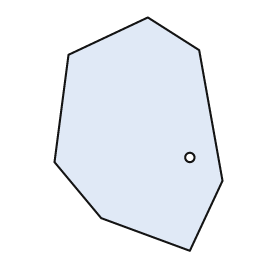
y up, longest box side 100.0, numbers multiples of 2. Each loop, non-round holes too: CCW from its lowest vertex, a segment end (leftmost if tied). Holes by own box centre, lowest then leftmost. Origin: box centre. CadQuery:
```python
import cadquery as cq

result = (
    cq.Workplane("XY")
    .moveTo(22.0, -50.0)
    .lineTo(36.0, -20.0)
    .lineTo(26.0, 36.0)
    .lineTo(4.0, 50.0)
    .lineTo(-30.0, 34.0)
    .lineTo(-36.0, -12.0)
    .lineTo(-16.0, -36.0)
    .close()
    .moveTo(22.0, -10.0)
    .circle(2.0)
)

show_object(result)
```